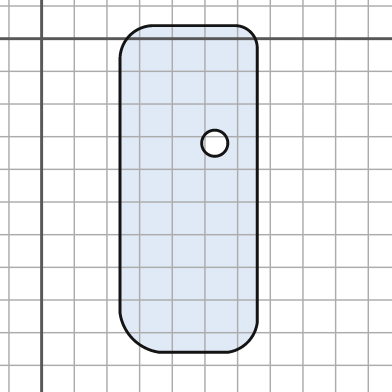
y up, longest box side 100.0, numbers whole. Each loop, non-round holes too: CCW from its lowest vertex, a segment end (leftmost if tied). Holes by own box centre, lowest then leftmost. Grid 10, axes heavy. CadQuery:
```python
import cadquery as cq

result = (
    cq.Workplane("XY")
    .moveTo(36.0, -96.0)
    .lineTo(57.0, -96.0)
    .threePointArc((63.0, -93.0), (66.0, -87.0))
    .lineTo(66.0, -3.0)
    .threePointArc((64.0, 2.0), (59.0, 4.0))
    .lineTo(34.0, 4.0)
    .threePointArc((27.0, 1.0), (24.0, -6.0))
    .lineTo(24.0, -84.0)
    .threePointArc((28.0, -92.0), (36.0, -96.0))
    .close()
    .moveTo(53.0, -32.0)
    .circle(4.0)
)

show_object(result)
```